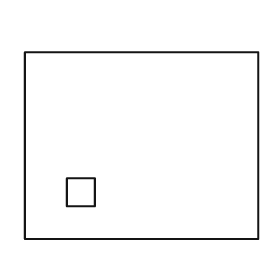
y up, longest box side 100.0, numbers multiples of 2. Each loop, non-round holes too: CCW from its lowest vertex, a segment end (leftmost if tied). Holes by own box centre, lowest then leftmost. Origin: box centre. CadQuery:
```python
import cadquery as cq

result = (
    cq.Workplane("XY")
    .moveTo(-50.0, -40.0)
    .lineTo(50.0, -40.0)
    .lineTo(50.0, 40.0)
    .lineTo(-50.0, 40.0)
    .close()
    .moveTo(-32.0, -26.0)
    .lineTo(-20.0, -26.0)
    .lineTo(-20.0, -14.0)
    .lineTo(-32.0, -14.0)
    .close()
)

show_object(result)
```